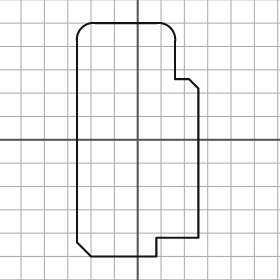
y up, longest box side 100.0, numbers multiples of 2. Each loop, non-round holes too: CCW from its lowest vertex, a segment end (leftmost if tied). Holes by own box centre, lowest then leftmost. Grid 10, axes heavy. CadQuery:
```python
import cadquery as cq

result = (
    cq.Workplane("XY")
    .moveTo(-20.0, -50.0)
    .lineTo(8.0, -50.0)
    .lineTo(8.0, -42.0)
    .lineTo(26.0, -42.0)
    .lineTo(26.0, 22.0)
    .lineTo(22.0, 26.0)
    .lineTo(16.0, 26.0)
    .lineTo(16.0, 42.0)
    .threePointArc((14.0, 48.0), (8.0, 50.0))
    .lineTo(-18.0, 50.0)
    .threePointArc((-24.0, 48.0), (-26.0, 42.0))
    .lineTo(-26.0, -44.0)
    .close()
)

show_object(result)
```